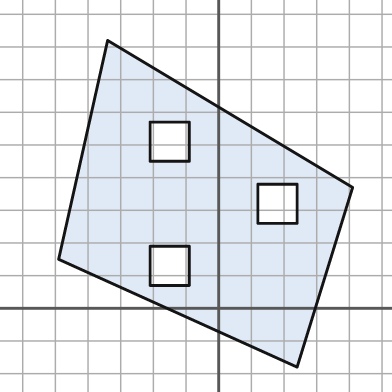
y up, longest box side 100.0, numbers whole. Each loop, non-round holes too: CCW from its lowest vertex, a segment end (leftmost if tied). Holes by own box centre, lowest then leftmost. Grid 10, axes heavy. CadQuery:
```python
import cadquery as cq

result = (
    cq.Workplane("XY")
    .moveTo(24.0, -18.0)
    .lineTo(41.0, 37.0)
    .lineTo(-34.0, 82.0)
    .lineTo(-49.0, 15.0)
    .close()
    .moveTo(-21.0, 7.0)
    .lineTo(-9.0, 7.0)
    .lineTo(-9.0, 19.0)
    .lineTo(-21.0, 19.0)
    .close()
    .moveTo(12.0, 26.0)
    .lineTo(24.0, 26.0)
    .lineTo(24.0, 38.0)
    .lineTo(12.0, 38.0)
    .close()
    .moveTo(-21.0, 45.0)
    .lineTo(-9.0, 45.0)
    .lineTo(-9.0, 57.0)
    .lineTo(-21.0, 57.0)
    .close()
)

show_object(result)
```